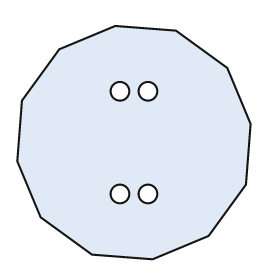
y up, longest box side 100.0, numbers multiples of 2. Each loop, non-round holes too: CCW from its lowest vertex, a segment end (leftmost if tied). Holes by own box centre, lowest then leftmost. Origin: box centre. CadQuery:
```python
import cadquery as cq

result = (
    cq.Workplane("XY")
    .moveTo(8.0, -50.0)
    .lineTo(32.0, -40.0)
    .lineTo(48.0, -18.0)
    .lineTo(50.0, 8.0)
    .lineTo(40.0, 32.0)
    .lineTo(18.0, 48.0)
    .lineTo(-8.0, 50.0)
    .lineTo(-32.0, 40.0)
    .lineTo(-48.0, 18.0)
    .lineTo(-50.0, -8.0)
    .lineTo(-40.0, -32.0)
    .lineTo(-18.0, -48.0)
    .close()
    .moveTo(-6.0, -22.0)
    .circle(4.0)
    .moveTo(6.0, -22.0)
    .circle(4.0)
    .moveTo(-6.0, 22.0)
    .circle(4.0)
    .moveTo(6.0, 22.0)
    .circle(4.0)
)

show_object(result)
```